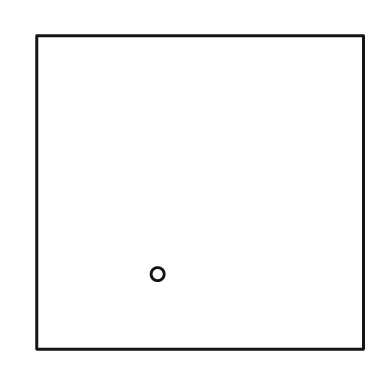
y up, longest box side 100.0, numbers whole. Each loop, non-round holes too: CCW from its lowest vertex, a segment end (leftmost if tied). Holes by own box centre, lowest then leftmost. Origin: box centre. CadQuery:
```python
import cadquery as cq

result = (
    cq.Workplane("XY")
    .moveTo(-50.0, -48.0)
    .lineTo(50.0, -48.0)
    .lineTo(50.0, 48.0)
    .lineTo(-50.0, 48.0)
    .close()
    .moveTo(-13.0, -25.0)
    .circle(2.0)
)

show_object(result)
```